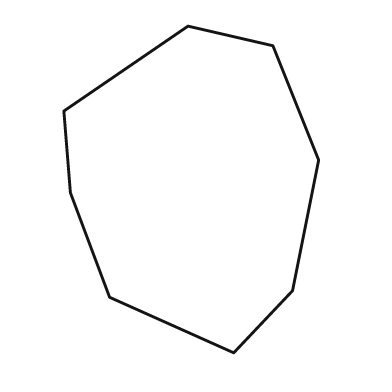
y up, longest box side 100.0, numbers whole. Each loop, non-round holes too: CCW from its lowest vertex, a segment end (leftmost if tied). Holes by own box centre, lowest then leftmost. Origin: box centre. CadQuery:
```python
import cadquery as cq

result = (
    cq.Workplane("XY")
    .moveTo(13.0, -50.0)
    .lineTo(31.0, -31.0)
    .lineTo(39.0, 9.0)
    .lineTo(25.0, 44.0)
    .lineTo(-1.0, 50.0)
    .lineTo(-39.0, 24.0)
    .lineTo(-37.0, -1.0)
    .lineTo(-25.0, -33.0)
    .close()
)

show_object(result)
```